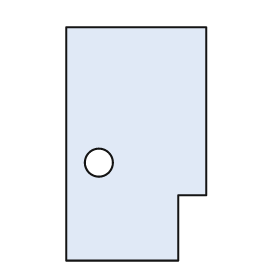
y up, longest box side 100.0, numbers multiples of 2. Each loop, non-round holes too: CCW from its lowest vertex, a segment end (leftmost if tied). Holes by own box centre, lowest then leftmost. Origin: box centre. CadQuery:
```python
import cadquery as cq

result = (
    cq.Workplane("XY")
    .moveTo(-30.0, -50.0)
    .lineTo(18.0, -50.0)
    .lineTo(18.0, -22.0)
    .lineTo(30.0, -22.0)
    .lineTo(30.0, 50.0)
    .lineTo(-30.0, 50.0)
    .close()
    .moveTo(-16.0, -8.0)
    .circle(6.0)
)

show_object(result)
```